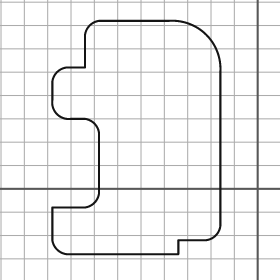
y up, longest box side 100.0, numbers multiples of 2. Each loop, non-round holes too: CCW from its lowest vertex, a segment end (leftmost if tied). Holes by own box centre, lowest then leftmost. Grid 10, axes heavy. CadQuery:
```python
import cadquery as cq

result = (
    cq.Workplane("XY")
    .moveTo(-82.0, -28.0)
    .lineTo(-34.0, -28.0)
    .lineTo(-34.0, -22.0)
    .lineTo(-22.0, -22.0)
    .threePointArc((-18.0, -20.0), (-16.0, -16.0))
    .lineTo(-16.0, 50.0)
    .threePointArc((-22.0, 66.0), (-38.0, 72.0))
    .lineTo(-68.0, 72.0)
    .threePointArc((-72.0, 70.0), (-74.0, 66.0))
    .lineTo(-74.0, 52.0)
    .lineTo(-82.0, 52.0)
    .threePointArc((-86.0, 50.0), (-88.0, 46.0))
    .lineTo(-88.0, 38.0)
    .threePointArc((-86.0, 32.0), (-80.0, 30.0))
    .lineTo(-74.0, 30.0)
    .threePointArc((-70.0, 28.0), (-68.0, 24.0))
    .lineTo(-68.0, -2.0)
    .threePointArc((-70.0, -6.0), (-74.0, -8.0))
    .lineTo(-88.0, -8.0)
    .lineTo(-88.0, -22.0)
    .threePointArc((-86.0, -26.0), (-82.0, -28.0))
    .close()
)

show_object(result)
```